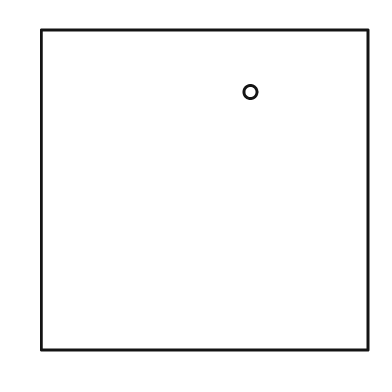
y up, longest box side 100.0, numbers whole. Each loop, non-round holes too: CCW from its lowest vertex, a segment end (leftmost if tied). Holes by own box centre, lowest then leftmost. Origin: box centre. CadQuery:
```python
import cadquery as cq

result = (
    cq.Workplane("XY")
    .moveTo(-50.0, -49.0)
    .lineTo(50.0, -49.0)
    .lineTo(50.0, 49.0)
    .lineTo(-50.0, 49.0)
    .close()
    .moveTo(14.0, 30.0)
    .circle(2.0)
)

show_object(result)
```